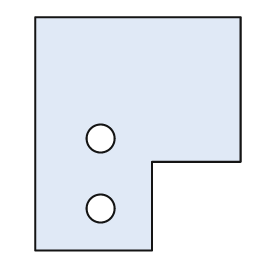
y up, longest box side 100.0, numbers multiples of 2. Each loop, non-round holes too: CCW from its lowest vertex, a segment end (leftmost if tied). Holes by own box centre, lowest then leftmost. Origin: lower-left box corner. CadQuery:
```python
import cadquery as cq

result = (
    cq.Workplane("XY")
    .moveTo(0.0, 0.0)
    .lineTo(50.0, 0.0)
    .lineTo(50.0, 38.0)
    .lineTo(88.0, 38.0)
    .lineTo(88.0, 100.0)
    .lineTo(0.0, 100.0)
    .close()
    .moveTo(28.0, 18.0)
    .circle(6.0)
    .moveTo(28.0, 48.0)
    .circle(6.0)
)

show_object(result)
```